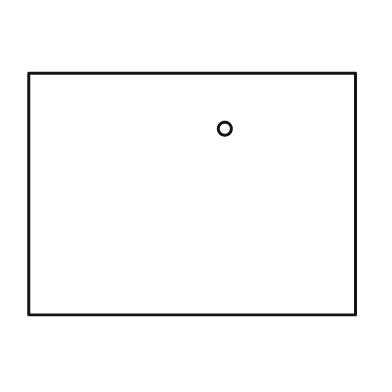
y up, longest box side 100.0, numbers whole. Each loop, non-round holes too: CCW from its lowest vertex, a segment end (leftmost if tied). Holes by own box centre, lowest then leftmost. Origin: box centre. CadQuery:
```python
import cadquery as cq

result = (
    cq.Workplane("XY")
    .moveTo(-50.0, -37.0)
    .lineTo(50.0, -37.0)
    .lineTo(50.0, 37.0)
    .lineTo(-50.0, 37.0)
    .close()
    .moveTo(10.0, 20.0)
    .circle(2.0)
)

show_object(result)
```